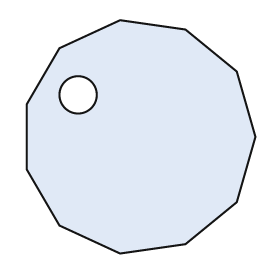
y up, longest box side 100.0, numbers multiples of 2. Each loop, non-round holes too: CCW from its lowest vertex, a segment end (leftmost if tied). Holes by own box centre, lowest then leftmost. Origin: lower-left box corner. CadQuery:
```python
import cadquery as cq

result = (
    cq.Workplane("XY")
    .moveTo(40.0, 0.0)
    .lineTo(68.0, 4.0)
    .lineTo(90.0, 22.0)
    .lineTo(98.0, 50.0)
    .lineTo(90.0, 78.0)
    .lineTo(68.0, 96.0)
    .lineTo(40.0, 100.0)
    .lineTo(14.0, 88.0)
    .lineTo(0.0, 64.0)
    .lineTo(0.0, 36.0)
    .lineTo(14.0, 12.0)
    .close()
    .moveTo(22.0, 68.0)
    .circle(8.0)
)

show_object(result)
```